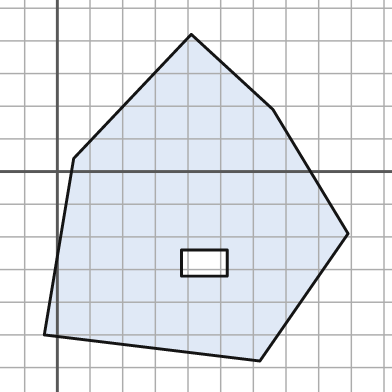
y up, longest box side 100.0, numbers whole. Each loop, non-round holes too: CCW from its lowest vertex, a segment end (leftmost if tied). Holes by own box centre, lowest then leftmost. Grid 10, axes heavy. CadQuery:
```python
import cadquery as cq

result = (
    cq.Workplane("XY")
    .moveTo(62.0, -58.0)
    .lineTo(89.0, -19.0)
    .lineTo(66.0, 19.0)
    .lineTo(41.0, 42.0)
    .lineTo(5.0, 4.0)
    .lineTo(-4.0, -50.0)
    .close()
    .moveTo(38.0, -32.0)
    .lineTo(52.0, -32.0)
    .lineTo(52.0, -24.0)
    .lineTo(38.0, -24.0)
    .close()
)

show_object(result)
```